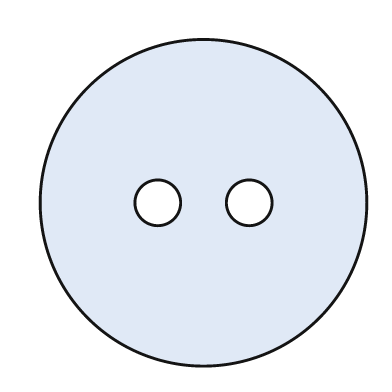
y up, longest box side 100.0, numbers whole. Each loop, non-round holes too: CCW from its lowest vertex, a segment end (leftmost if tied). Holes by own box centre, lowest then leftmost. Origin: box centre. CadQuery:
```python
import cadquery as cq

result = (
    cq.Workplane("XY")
    .moveTo(0.0, 0.0)
    .circle(50.0)
    .moveTo(-14.0, 0.0)
    .circle(7.0)
    .moveTo(14.0, 0.0)
    .circle(7.0)
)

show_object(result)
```